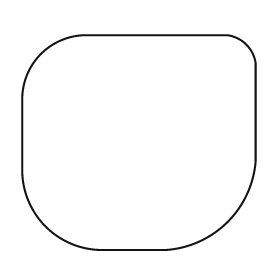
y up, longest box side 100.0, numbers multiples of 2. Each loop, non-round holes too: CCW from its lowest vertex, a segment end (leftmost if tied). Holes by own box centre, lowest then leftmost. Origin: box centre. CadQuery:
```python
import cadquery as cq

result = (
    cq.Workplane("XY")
    .moveTo(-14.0, -46.0)
    .lineTo(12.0, -46.0)
    .threePointArc((38.0, -34.0), (50.0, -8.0))
    .lineTo(50.0, 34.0)
    .threePointArc((46.0, 42.0), (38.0, 46.0))
    .lineTo(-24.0, 46.0)
    .threePointArc((-42.0, 38.0), (-50.0, 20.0))
    .lineTo(-50.0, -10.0)
    .threePointArc((-40.0, -36.0), (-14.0, -46.0))
    .close()
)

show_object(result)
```